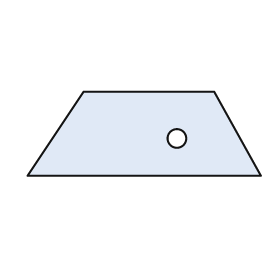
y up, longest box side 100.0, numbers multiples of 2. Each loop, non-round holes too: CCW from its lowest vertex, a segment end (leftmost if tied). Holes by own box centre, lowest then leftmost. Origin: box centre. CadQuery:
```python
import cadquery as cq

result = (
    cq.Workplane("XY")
    .moveTo(-50.0, -18.0)
    .lineTo(50.0, -18.0)
    .lineTo(30.0, 18.0)
    .lineTo(-26.0, 18.0)
    .close()
    .moveTo(14.0, -2.0)
    .circle(4.0)
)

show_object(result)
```